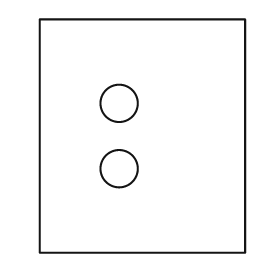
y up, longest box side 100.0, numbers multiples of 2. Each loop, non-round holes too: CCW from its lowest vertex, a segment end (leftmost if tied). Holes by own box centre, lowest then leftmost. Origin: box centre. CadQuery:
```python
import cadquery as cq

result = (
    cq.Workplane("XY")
    .moveTo(-44.0, -50.0)
    .lineTo(44.0, -50.0)
    .lineTo(44.0, 50.0)
    .lineTo(-44.0, 50.0)
    .close()
    .moveTo(-10.0, -14.0)
    .circle(8.0)
    .moveTo(-10.0, 14.0)
    .circle(8.0)
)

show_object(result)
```